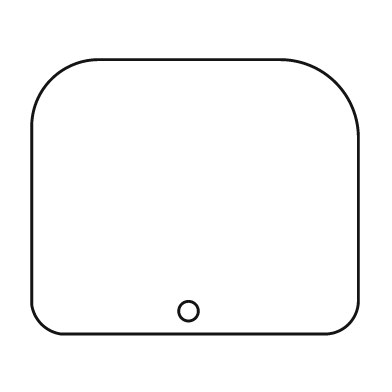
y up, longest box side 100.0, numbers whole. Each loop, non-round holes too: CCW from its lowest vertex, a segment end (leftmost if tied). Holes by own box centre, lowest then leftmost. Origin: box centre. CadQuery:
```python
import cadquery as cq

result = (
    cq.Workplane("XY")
    .moveTo(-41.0, -42.0)
    .lineTo(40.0, -42.0)
    .threePointArc((47.0, -39.0), (50.0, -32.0))
    .lineTo(50.0, 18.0)
    .threePointArc((43.0, 35.0), (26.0, 42.0))
    .lineTo(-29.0, 42.0)
    .threePointArc((-44.0, 36.0), (-50.0, 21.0))
    .lineTo(-50.0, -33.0)
    .threePointArc((-47.0, -39.0), (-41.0, -42.0))
    .close()
    .moveTo(-2.0, -35.0)
    .circle(3.0)
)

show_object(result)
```